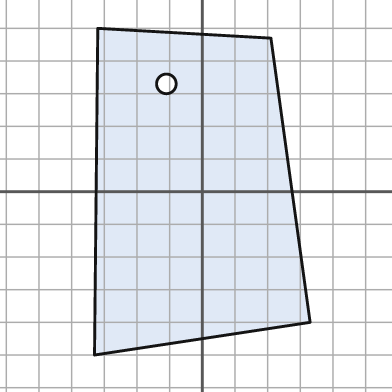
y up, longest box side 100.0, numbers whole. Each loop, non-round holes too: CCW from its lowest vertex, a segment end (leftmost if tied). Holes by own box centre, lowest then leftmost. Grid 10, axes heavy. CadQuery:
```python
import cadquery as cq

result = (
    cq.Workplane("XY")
    .moveTo(-33.0, -50.0)
    .lineTo(33.0, -40.0)
    .lineTo(21.0, 47.0)
    .lineTo(-32.0, 50.0)
    .close()
    .moveTo(-11.0, 33.0)
    .circle(3.0)
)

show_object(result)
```